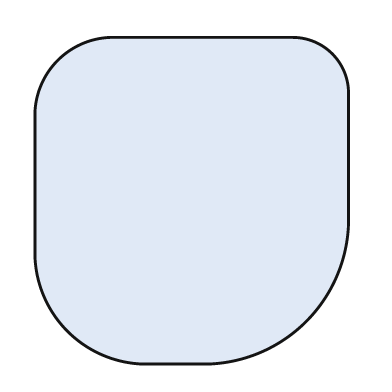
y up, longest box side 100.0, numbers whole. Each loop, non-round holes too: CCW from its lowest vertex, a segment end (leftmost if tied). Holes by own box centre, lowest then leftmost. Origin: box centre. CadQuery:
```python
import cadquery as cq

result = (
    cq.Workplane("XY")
    .moveTo(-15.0, -50.0)
    .lineTo(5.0, -50.0)
    .threePointArc((35.0, -37.0), (48.0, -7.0))
    .lineTo(48.0, 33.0)
    .threePointArc((43.0, 45.0), (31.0, 50.0))
    .lineTo(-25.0, 50.0)
    .threePointArc((-41.0, 43.0), (-48.0, 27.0))
    .lineTo(-48.0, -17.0)
    .threePointArc((-38.0, -40.0), (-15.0, -50.0))
    .close()
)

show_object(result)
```